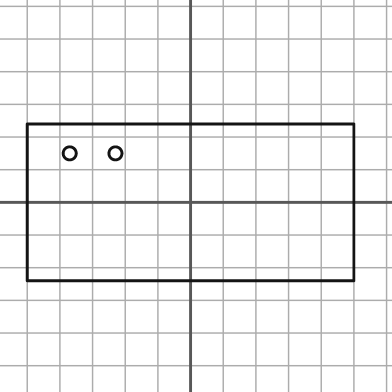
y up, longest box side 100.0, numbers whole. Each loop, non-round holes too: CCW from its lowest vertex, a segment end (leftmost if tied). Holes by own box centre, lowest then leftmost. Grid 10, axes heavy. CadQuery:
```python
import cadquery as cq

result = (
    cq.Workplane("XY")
    .moveTo(-50.0, -24.0)
    .lineTo(50.0, -24.0)
    .lineTo(50.0, 24.0)
    .lineTo(-50.0, 24.0)
    .close()
    .moveTo(-37.0, 15.0)
    .circle(2.0)
    .moveTo(-23.0, 15.0)
    .circle(2.0)
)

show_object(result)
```